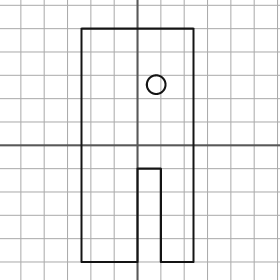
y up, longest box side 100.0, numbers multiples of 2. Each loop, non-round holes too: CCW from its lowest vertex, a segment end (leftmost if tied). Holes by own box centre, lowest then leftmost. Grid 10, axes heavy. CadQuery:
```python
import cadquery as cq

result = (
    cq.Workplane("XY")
    .moveTo(-24.0, -50.0)
    .lineTo(0.0, -50.0)
    .lineTo(0.0, -10.0)
    .lineTo(10.0, -10.0)
    .lineTo(10.0, -50.0)
    .lineTo(24.0, -50.0)
    .lineTo(24.0, 50.0)
    .lineTo(-24.0, 50.0)
    .close()
    .moveTo(8.0, 26.0)
    .circle(4.0)
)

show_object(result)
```